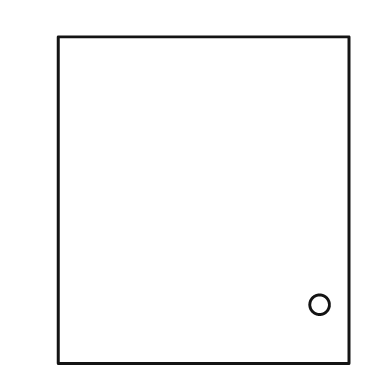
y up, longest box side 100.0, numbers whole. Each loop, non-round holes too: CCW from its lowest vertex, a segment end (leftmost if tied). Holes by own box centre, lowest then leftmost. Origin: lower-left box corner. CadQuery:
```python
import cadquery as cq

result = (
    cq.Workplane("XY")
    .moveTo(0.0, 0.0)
    .lineTo(89.0, 0.0)
    .lineTo(89.0, 100.0)
    .lineTo(0.0, 100.0)
    .close()
    .moveTo(80.0, 18.0)
    .circle(3.0)
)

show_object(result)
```